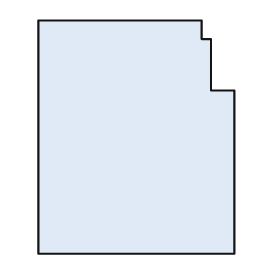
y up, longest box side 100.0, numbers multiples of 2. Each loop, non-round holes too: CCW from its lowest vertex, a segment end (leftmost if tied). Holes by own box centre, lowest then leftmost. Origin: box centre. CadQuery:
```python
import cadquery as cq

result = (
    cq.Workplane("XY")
    .moveTo(-42.0, -50.0)
    .lineTo(42.0, -50.0)
    .lineTo(42.0, 20.0)
    .lineTo(32.0, 20.0)
    .lineTo(32.0, 42.0)
    .lineTo(28.0, 42.0)
    .lineTo(28.0, 50.0)
    .lineTo(-42.0, 50.0)
    .close()
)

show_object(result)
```